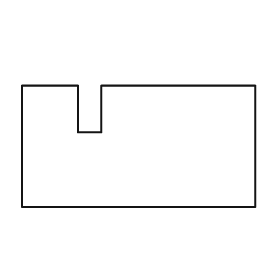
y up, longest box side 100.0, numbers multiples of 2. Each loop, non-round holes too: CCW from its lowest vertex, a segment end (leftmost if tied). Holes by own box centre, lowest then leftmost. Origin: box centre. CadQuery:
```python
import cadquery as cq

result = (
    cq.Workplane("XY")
    .moveTo(-50.0, -26.0)
    .lineTo(50.0, -26.0)
    .lineTo(50.0, 26.0)
    .lineTo(-16.0, 26.0)
    .lineTo(-16.0, 6.0)
    .lineTo(-26.0, 6.0)
    .lineTo(-26.0, 26.0)
    .lineTo(-50.0, 26.0)
    .close()
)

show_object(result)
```